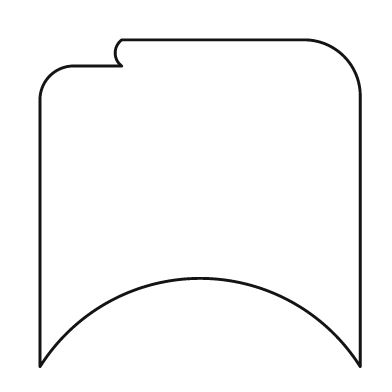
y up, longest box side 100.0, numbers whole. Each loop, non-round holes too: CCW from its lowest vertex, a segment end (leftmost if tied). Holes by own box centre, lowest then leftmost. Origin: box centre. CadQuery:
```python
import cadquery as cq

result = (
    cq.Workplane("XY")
    .moveTo(-49.0, -50.0)
    .threePointArc((0.0, -23.0), (49.0, -50.0))
    .lineTo(49.0, 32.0)
    .threePointArc((44.0, 45.0), (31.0, 50.0))
    .lineTo(-24.0, 50.0)
    .threePointArc((-26.0, 46.0), (-24.0, 42.0))
    .lineTo(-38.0, 42.0)
    .threePointArc((-46.0, 39.0), (-49.0, 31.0))
    .close()
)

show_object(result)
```